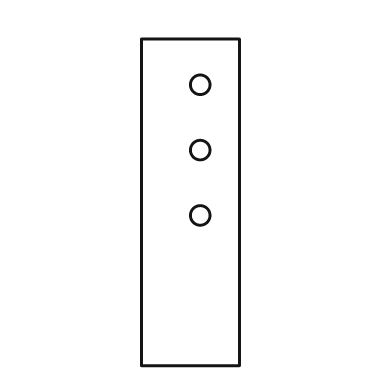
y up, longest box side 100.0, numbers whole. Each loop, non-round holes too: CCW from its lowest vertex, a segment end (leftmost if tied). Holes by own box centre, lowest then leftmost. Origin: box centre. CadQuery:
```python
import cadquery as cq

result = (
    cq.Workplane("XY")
    .moveTo(-15.0, -50.0)
    .lineTo(15.0, -50.0)
    .lineTo(15.0, 50.0)
    .lineTo(-15.0, 50.0)
    .close()
    .moveTo(3.0, -4.0)
    .circle(3.0)
    .moveTo(3.0, 16.0)
    .circle(3.0)
    .moveTo(3.0, 36.0)
    .circle(3.0)
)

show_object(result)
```